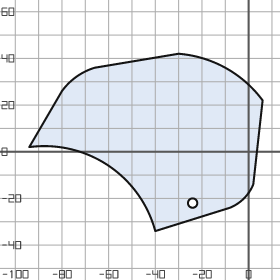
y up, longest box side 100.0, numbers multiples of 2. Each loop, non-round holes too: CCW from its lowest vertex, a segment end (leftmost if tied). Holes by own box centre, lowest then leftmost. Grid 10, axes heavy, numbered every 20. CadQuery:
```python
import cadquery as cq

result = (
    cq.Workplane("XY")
    .moveTo(-40.0, -34.0)
    .lineTo(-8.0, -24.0)
    .threePointArc((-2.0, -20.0), (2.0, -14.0))
    .lineTo(6.0, 22.0)
    .threePointArc((-10.0, 36.0), (-30.0, 42.0))
    .lineTo(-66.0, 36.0)
    .threePointArc((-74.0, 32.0), (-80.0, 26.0))
    .lineTo(-94.0, 2.0)
    .threePointArc((-60.0, -6.0), (-40.0, -34.0))
    .close()
    .moveTo(-24.0, -22.0)
    .circle(2.0)
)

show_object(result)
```